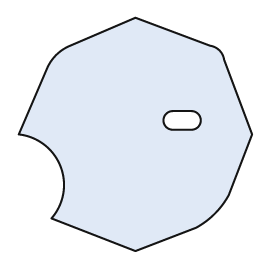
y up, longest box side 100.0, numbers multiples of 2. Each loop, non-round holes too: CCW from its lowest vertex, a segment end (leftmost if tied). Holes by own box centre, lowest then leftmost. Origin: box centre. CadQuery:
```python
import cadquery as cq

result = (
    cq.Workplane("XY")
    .moveTo(0.0, -50.0)
    .lineTo(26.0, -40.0)
    .threePointArc((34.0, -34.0), (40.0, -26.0))
    .lineTo(50.0, 0.0)
    .lineTo(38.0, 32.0)
    .threePointArc((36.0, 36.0), (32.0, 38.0))
    .lineTo(0.0, 50.0)
    .lineTo(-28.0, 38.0)
    .threePointArc((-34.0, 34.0), (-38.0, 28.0))
    .lineTo(-50.0, 0.0)
    .threePointArc((-32.0, -14.0), (-36.0, -36.0))
    .close()
    .moveTo(16.0, 2.0)
    .lineTo(24.0, 2.0)
    .threePointArc((28.0, 6.0), (24.0, 10.0))
    .lineTo(16.0, 10.0)
    .threePointArc((12.0, 6.0), (16.0, 2.0))
    .close()
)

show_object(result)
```